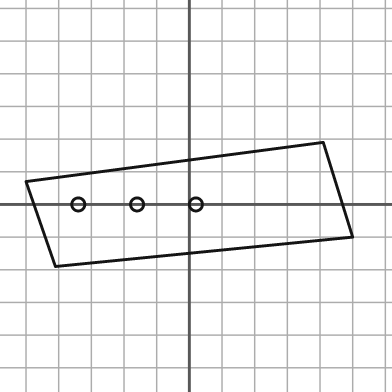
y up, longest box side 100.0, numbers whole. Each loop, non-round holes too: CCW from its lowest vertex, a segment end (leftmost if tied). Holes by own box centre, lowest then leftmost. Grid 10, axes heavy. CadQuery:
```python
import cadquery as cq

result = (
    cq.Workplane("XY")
    .moveTo(-41.0, -19.0)
    .lineTo(50.0, -10.0)
    .lineTo(41.0, 19.0)
    .lineTo(-50.0, 7.0)
    .close()
    .moveTo(-34.0, 0.0)
    .circle(2.0)
    .moveTo(-16.0, 0.0)
    .circle(2.0)
    .moveTo(2.0, 0.0)
    .circle(2.0)
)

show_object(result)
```